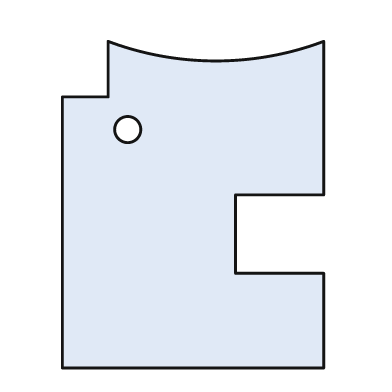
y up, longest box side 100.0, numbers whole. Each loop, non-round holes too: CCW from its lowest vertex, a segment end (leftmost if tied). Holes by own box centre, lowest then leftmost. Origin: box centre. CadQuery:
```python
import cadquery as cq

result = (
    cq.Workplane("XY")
    .moveTo(-40.0, -50.0)
    .lineTo(40.0, -50.0)
    .lineTo(40.0, -21.0)
    .lineTo(13.0, -21.0)
    .lineTo(13.0, 3.0)
    .lineTo(40.0, 3.0)
    .lineTo(40.0, 50.0)
    .threePointArc((7.0, 44.0), (-26.0, 50.0))
    .lineTo(-26.0, 33.0)
    .lineTo(-40.0, 33.0)
    .close()
    .moveTo(-20.0, 23.0)
    .circle(4.0)
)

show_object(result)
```